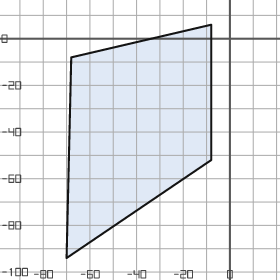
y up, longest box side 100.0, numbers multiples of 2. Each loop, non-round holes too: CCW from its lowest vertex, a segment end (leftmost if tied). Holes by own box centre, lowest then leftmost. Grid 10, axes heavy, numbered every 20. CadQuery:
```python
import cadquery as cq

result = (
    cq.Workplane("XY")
    .moveTo(-70.0, -94.0)
    .lineTo(-8.0, -52.0)
    .lineTo(-8.0, 6.0)
    .lineTo(-68.0, -8.0)
    .close()
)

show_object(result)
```